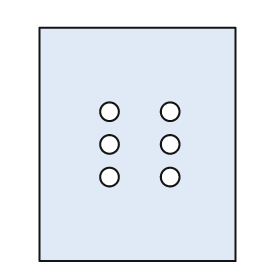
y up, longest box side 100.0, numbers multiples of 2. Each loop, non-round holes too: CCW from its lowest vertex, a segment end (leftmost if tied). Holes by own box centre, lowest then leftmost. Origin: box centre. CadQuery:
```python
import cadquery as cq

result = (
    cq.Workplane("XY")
    .moveTo(-42.0, -50.0)
    .lineTo(42.0, -50.0)
    .lineTo(42.0, 50.0)
    .lineTo(-42.0, 50.0)
    .close()
    .moveTo(-12.0, -14.0)
    .circle(4.0)
    .moveTo(14.0, -14.0)
    .circle(4.0)
    .moveTo(-12.0, 0.0)
    .circle(4.0)
    .moveTo(14.0, 0.0)
    .circle(4.0)
    .moveTo(-12.0, 14.0)
    .circle(4.0)
    .moveTo(14.0, 14.0)
    .circle(4.0)
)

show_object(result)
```